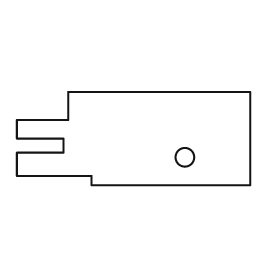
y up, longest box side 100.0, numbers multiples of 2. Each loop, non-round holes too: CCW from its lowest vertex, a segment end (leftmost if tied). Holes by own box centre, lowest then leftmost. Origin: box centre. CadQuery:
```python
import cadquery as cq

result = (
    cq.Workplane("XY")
    .moveTo(-18.0, -20.0)
    .lineTo(50.0, -20.0)
    .lineTo(50.0, 20.0)
    .lineTo(-28.0, 20.0)
    .lineTo(-28.0, 8.0)
    .lineTo(-50.0, 8.0)
    .lineTo(-50.0, 0.0)
    .lineTo(-30.0, 0.0)
    .lineTo(-30.0, -6.0)
    .lineTo(-50.0, -6.0)
    .lineTo(-50.0, -16.0)
    .lineTo(-18.0, -16.0)
    .close()
    .moveTo(22.0, -8.0)
    .circle(4.0)
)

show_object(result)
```